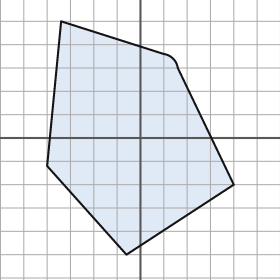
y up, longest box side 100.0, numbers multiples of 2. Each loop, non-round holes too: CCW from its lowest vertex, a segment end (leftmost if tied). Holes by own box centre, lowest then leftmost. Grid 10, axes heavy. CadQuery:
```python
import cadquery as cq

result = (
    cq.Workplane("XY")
    .moveTo(-6.0, -50.0)
    .lineTo(40.0, -20.0)
    .lineTo(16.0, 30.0)
    .threePointArc((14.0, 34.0), (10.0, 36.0))
    .lineTo(-34.0, 50.0)
    .lineTo(-40.0, -12.0)
    .close()
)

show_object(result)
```